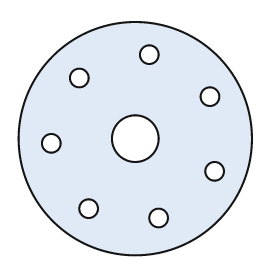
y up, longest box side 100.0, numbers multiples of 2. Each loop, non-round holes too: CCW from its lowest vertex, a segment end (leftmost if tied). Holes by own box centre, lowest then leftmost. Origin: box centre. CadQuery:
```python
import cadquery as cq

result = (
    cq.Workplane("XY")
    .moveTo(0.0, 0.0)
    .circle(50.0)
    .moveTo(10.0, -34.0)
    .circle(4.0)
    .moveTo(-20.0, -30.0)
    .circle(4.0)
    .moveTo(34.0, -14.0)
    .circle(4.0)
    .moveTo(-36.0, -2.0)
    .circle(4.0)
    .moveTo(0.0, 0.0)
    .circle(10.0)
    .moveTo(32.0, 18.0)
    .circle(4.0)
    .moveTo(-24.0, 26.0)
    .circle(4.0)
    .moveTo(6.0, 36.0)
    .circle(4.0)
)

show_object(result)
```